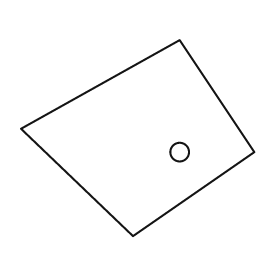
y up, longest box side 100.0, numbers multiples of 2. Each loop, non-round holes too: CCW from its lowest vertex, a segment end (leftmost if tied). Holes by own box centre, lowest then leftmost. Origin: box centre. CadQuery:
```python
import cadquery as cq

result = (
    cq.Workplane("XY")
    .moveTo(-2.0, -42.0)
    .lineTo(50.0, -6.0)
    .lineTo(18.0, 42.0)
    .lineTo(-50.0, 4.0)
    .close()
    .moveTo(18.0, -6.0)
    .circle(4.0)
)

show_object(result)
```